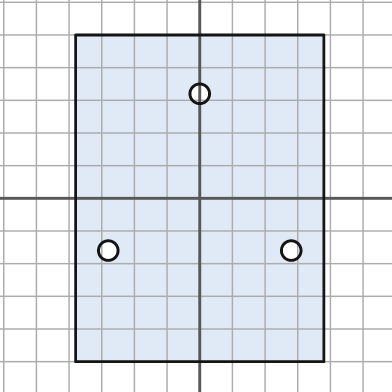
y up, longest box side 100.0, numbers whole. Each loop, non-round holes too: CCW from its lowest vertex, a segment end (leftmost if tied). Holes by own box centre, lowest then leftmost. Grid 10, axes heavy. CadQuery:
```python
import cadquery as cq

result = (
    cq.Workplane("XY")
    .moveTo(-38.0, -50.0)
    .lineTo(38.0, -50.0)
    .lineTo(38.0, 50.0)
    .lineTo(-38.0, 50.0)
    .close()
    .moveTo(-28.0, -16.0)
    .circle(3.0)
    .moveTo(28.0, -16.0)
    .circle(3.0)
    .moveTo(0.0, 32.0)
    .circle(3.0)
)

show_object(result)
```